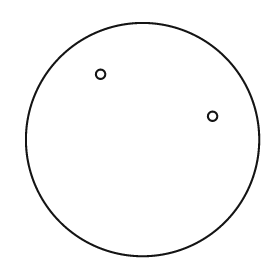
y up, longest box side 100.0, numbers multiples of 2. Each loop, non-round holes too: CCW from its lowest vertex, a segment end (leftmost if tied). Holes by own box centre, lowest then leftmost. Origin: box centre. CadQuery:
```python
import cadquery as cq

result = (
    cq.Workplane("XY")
    .moveTo(0.0, 0.0)
    .circle(50.0)
    .moveTo(30.0, 10.0)
    .circle(2.0)
    .moveTo(-18.0, 28.0)
    .circle(2.0)
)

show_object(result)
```